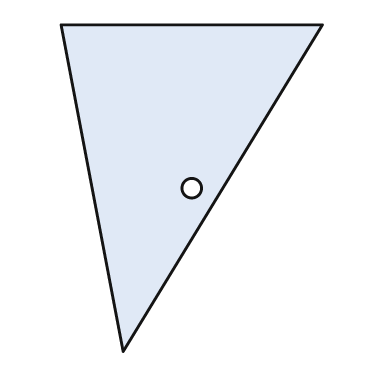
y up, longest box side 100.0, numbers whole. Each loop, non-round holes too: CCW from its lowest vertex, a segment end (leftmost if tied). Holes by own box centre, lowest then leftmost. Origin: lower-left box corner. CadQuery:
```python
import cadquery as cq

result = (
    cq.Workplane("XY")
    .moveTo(19.0, 0.0)
    .lineTo(80.0, 100.0)
    .lineTo(0.0, 100.0)
    .close()
    .moveTo(40.0, 50.0)
    .circle(3.0)
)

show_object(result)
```